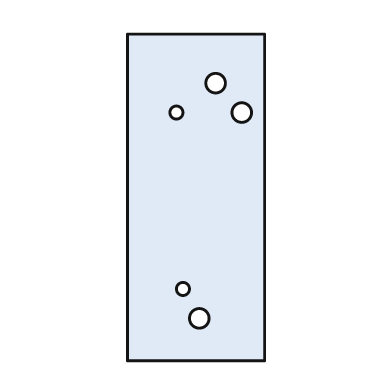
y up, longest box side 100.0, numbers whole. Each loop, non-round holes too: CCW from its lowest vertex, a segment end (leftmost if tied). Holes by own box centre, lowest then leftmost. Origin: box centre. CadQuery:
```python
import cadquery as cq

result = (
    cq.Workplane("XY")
    .moveTo(-21.0, -50.0)
    .lineTo(21.0, -50.0)
    .lineTo(21.0, 50.0)
    .lineTo(-21.0, 50.0)
    .close()
    .moveTo(1.0, -37.0)
    .circle(3.0)
    .moveTo(-4.0, -28.0)
    .circle(2.0)
    .moveTo(-6.0, 26.0)
    .circle(2.0)
    .moveTo(14.0, 26.0)
    .circle(3.0)
    .moveTo(6.0, 35.0)
    .circle(3.0)
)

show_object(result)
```